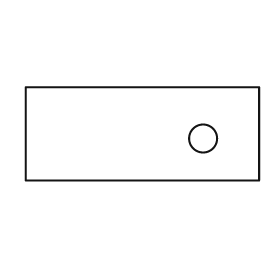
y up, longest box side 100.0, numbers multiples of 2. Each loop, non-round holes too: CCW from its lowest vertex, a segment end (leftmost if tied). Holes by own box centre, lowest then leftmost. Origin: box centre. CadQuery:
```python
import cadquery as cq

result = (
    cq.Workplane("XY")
    .moveTo(-50.0, -20.0)
    .lineTo(50.0, -20.0)
    .lineTo(50.0, 20.0)
    .lineTo(-50.0, 20.0)
    .close()
    .moveTo(26.0, -2.0)
    .circle(6.0)
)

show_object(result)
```